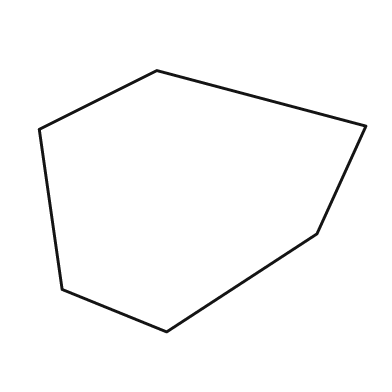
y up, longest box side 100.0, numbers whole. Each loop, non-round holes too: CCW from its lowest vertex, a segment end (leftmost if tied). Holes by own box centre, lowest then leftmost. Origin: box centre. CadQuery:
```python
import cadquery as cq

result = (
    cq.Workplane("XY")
    .moveTo(-11.0, -40.0)
    .lineTo(35.0, -10.0)
    .lineTo(50.0, 23.0)
    .lineTo(-14.0, 40.0)
    .lineTo(-50.0, 22.0)
    .lineTo(-43.0, -27.0)
    .close()
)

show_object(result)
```